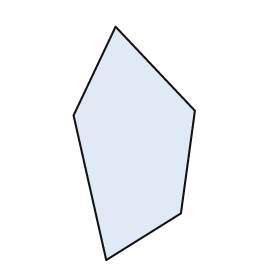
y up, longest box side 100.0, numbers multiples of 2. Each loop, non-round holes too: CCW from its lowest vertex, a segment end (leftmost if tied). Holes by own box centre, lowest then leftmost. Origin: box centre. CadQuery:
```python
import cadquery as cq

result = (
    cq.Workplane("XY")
    .moveTo(-12.0, -50.0)
    .lineTo(20.0, -30.0)
    .lineTo(26.0, 14.0)
    .lineTo(-8.0, 50.0)
    .lineTo(-26.0, 12.0)
    .close()
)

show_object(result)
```